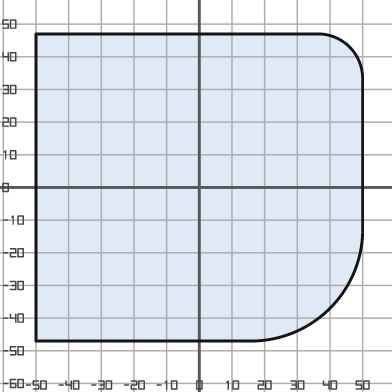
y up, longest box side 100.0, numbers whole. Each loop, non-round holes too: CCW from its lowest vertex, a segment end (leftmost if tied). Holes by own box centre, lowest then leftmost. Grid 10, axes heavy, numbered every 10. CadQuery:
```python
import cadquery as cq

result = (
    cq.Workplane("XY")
    .moveTo(-50.0, -47.0)
    .lineTo(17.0, -47.0)
    .threePointArc((40.0, -37.0), (50.0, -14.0))
    .lineTo(50.0, 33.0)
    .threePointArc((46.0, 43.0), (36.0, 47.0))
    .lineTo(-50.0, 47.0)
    .close()
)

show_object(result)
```